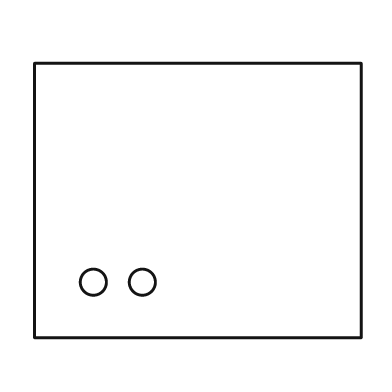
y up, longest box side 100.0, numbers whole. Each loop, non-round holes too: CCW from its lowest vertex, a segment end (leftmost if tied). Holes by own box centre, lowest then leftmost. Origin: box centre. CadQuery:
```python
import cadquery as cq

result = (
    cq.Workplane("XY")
    .moveTo(-50.0, -42.0)
    .lineTo(50.0, -42.0)
    .lineTo(50.0, 42.0)
    .lineTo(-50.0, 42.0)
    .close()
    .moveTo(-32.0, -25.0)
    .circle(4.0)
    .moveTo(-17.0, -25.0)
    .circle(4.0)
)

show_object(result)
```